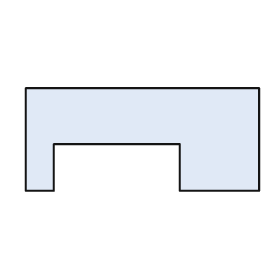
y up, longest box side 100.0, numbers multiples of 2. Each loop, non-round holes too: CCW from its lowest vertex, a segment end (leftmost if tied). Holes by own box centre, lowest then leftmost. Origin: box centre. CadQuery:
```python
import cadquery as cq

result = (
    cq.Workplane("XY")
    .moveTo(-50.0, -22.0)
    .lineTo(-38.0, -22.0)
    .lineTo(-38.0, -2.0)
    .lineTo(16.0, -2.0)
    .lineTo(16.0, -22.0)
    .lineTo(50.0, -22.0)
    .lineTo(50.0, 22.0)
    .lineTo(-50.0, 22.0)
    .close()
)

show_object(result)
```